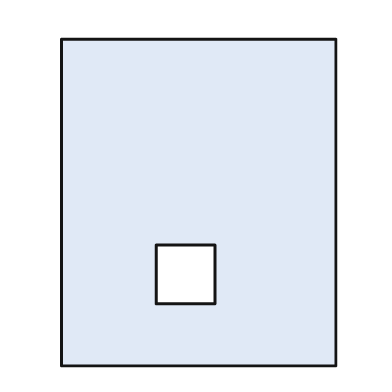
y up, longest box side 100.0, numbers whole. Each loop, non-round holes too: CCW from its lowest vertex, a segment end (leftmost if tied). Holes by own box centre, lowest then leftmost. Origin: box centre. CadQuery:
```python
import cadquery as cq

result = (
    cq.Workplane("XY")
    .moveTo(-42.0, -50.0)
    .lineTo(42.0, -50.0)
    .lineTo(42.0, 50.0)
    .lineTo(-42.0, 50.0)
    .close()
    .moveTo(-13.0, -31.0)
    .lineTo(5.0, -31.0)
    .lineTo(5.0, -13.0)
    .lineTo(-13.0, -13.0)
    .close()
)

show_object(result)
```